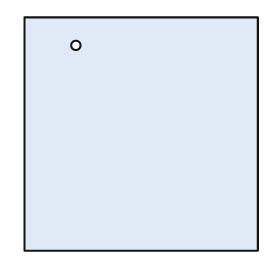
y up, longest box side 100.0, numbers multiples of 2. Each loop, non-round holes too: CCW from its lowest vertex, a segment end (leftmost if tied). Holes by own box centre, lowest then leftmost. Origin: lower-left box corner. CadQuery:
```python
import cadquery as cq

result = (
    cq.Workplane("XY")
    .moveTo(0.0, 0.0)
    .lineTo(100.0, 0.0)
    .lineTo(100.0, 100.0)
    .lineTo(0.0, 100.0)
    .close()
    .moveTo(22.0, 88.0)
    .circle(2.0)
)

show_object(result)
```